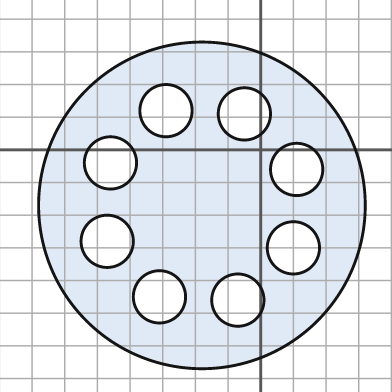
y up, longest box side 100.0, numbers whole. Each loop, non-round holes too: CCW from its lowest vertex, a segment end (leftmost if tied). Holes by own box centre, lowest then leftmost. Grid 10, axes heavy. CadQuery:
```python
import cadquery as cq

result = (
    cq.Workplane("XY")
    .moveTo(-18.0, -17.0)
    .circle(50.0)
    .moveTo(-7.0, -46.0)
    .circle(8.0)
    .moveTo(-31.0, -45.0)
    .circle(8.0)
    .moveTo(10.0, -30.0)
    .circle(8.0)
    .moveTo(-47.0, -28.0)
    .circle(8.0)
    .moveTo(11.0, -6.0)
    .circle(8.0)
    .moveTo(-46.0, -4.0)
    .circle(8.0)
    .moveTo(-5.0, 11.0)
    .circle(8.0)
    .moveTo(-29.0, 12.0)
    .circle(8.0)
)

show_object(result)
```